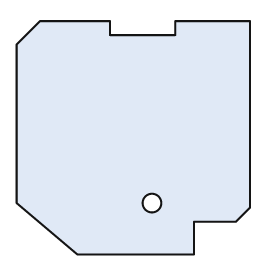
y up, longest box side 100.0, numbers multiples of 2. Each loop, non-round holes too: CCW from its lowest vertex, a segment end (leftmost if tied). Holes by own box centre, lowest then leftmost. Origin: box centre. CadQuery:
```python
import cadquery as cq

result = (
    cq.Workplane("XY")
    .moveTo(-24.0, -50.0)
    .lineTo(26.0, -50.0)
    .lineTo(26.0, -36.0)
    .lineTo(44.0, -36.0)
    .lineTo(50.0, -30.0)
    .lineTo(50.0, 50.0)
    .lineTo(18.0, 50.0)
    .lineTo(18.0, 44.0)
    .lineTo(-10.0, 44.0)
    .lineTo(-10.0, 50.0)
    .lineTo(-40.0, 50.0)
    .lineTo(-50.0, 40.0)
    .lineTo(-50.0, -28.0)
    .close()
    .moveTo(8.0, -28.0)
    .circle(4.0)
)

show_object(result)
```